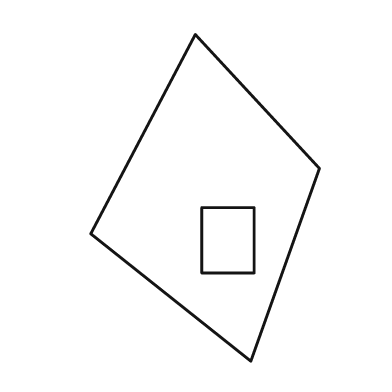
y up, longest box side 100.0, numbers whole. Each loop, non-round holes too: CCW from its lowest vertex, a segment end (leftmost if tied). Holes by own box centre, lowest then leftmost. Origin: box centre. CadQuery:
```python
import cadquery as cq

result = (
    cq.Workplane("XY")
    .moveTo(14.0, -50.0)
    .lineTo(35.0, 9.0)
    .lineTo(-3.0, 50.0)
    .lineTo(-35.0, -11.0)
    .close()
    .moveTo(-1.0, -23.0)
    .lineTo(15.0, -23.0)
    .lineTo(15.0, -3.0)
    .lineTo(-1.0, -3.0)
    .close()
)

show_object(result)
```